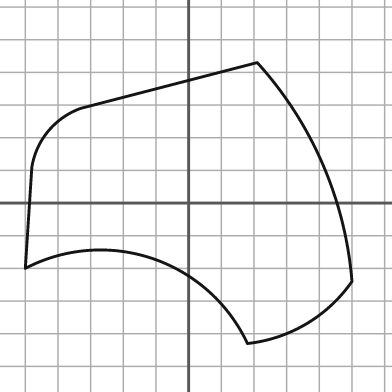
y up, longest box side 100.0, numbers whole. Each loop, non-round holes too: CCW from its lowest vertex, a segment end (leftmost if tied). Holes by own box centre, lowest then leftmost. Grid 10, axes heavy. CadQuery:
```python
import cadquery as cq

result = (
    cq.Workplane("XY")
    .moveTo(18.0, -43.0)
    .threePointArc((36.0, -37.0), (50.0, -24.0))
    .threePointArc((41.0, 12.0), (21.0, 43.0))
    .lineTo(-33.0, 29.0)
    .threePointArc((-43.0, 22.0), (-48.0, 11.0))
    .lineTo(-50.0, -20.0)
    .threePointArc((-11.0, -17.0), (18.0, -43.0))
    .close()
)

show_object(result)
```